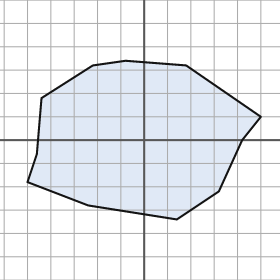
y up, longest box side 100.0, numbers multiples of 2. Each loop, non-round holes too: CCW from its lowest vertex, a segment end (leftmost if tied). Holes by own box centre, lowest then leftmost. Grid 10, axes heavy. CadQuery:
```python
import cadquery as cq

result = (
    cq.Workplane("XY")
    .moveTo(14.0, -34.0)
    .lineTo(32.0, -22.0)
    .lineTo(42.0, 0.0)
    .lineTo(50.0, 10.0)
    .lineTo(18.0, 32.0)
    .lineTo(-8.0, 34.0)
    .lineTo(-22.0, 32.0)
    .lineTo(-44.0, 18.0)
    .lineTo(-46.0, -6.0)
    .lineTo(-50.0, -18.0)
    .lineTo(-24.0, -28.0)
    .close()
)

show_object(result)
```